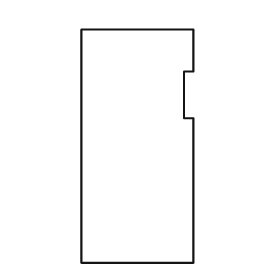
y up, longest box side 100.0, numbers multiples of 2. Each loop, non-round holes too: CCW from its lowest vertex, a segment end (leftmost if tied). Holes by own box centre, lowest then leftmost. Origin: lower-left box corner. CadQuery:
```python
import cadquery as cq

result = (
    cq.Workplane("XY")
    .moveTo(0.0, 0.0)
    .lineTo(48.0, 0.0)
    .lineTo(48.0, 62.0)
    .lineTo(44.0, 62.0)
    .lineTo(44.0, 82.0)
    .lineTo(48.0, 82.0)
    .lineTo(48.0, 100.0)
    .lineTo(0.0, 100.0)
    .close()
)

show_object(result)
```